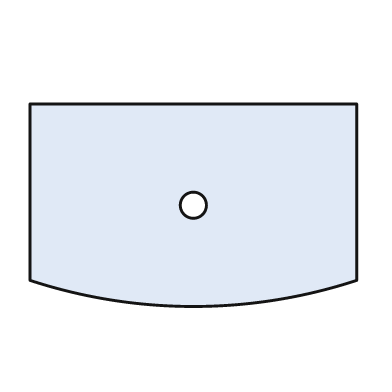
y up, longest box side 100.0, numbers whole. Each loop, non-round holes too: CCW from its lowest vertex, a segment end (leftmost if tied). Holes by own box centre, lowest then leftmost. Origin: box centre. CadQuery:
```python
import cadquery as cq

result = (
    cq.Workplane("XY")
    .moveTo(-50.0, -23.0)
    .threePointArc((0.0, -31.0), (50.0, -23.0))
    .lineTo(50.0, 31.0)
    .lineTo(-50.0, 31.0)
    .close()
    .moveTo(0.0, 0.0)
    .circle(4.0)
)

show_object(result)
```